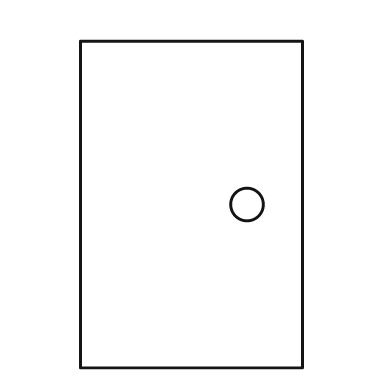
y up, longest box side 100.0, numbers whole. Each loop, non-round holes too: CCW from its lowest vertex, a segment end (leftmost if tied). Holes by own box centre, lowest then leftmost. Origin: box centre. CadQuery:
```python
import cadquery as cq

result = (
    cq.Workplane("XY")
    .moveTo(-34.0, -50.0)
    .lineTo(34.0, -50.0)
    .lineTo(34.0, 50.0)
    .lineTo(-34.0, 50.0)
    .close()
    .moveTo(17.0, 0.0)
    .circle(5.0)
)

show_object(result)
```